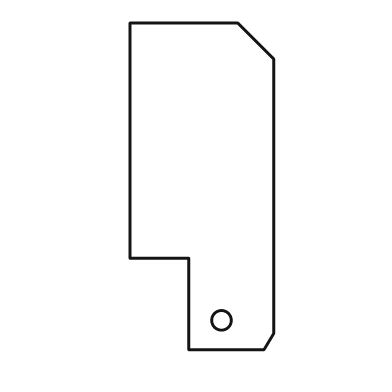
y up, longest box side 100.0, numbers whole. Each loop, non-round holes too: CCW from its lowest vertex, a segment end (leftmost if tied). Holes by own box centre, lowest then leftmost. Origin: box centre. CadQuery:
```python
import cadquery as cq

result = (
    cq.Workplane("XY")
    .moveTo(-4.0, -50.0)
    .lineTo(19.0, -50.0)
    .lineTo(22.0, -45.0)
    .lineTo(22.0, 39.0)
    .lineTo(11.0, 50.0)
    .lineTo(-22.0, 50.0)
    .lineTo(-22.0, -22.0)
    .lineTo(-4.0, -22.0)
    .close()
    .moveTo(6.0, -41.0)
    .circle(3.0)
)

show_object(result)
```